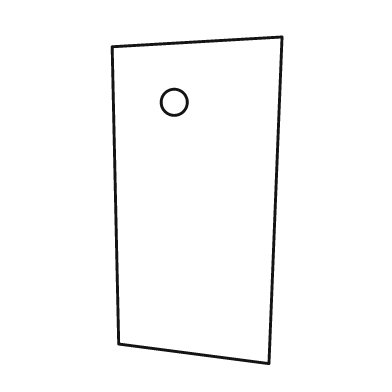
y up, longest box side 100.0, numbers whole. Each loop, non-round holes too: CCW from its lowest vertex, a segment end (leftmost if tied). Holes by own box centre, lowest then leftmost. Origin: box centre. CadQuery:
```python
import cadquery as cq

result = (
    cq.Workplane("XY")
    .moveTo(22.0, -50.0)
    .lineTo(26.0, 50.0)
    .lineTo(-26.0, 47.0)
    .lineTo(-24.0, -44.0)
    .close()
    .moveTo(-7.0, 30.0)
    .circle(4.0)
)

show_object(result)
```